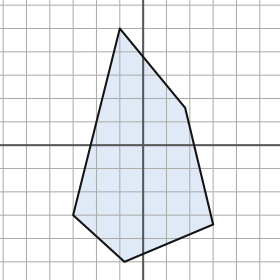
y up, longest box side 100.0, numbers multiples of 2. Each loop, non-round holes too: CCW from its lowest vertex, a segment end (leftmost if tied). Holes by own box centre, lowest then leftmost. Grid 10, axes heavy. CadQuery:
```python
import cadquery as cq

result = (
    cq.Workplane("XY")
    .moveTo(-8.0, -50.0)
    .lineTo(30.0, -34.0)
    .lineTo(18.0, 16.0)
    .lineTo(-10.0, 50.0)
    .lineTo(-30.0, -30.0)
    .close()
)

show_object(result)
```